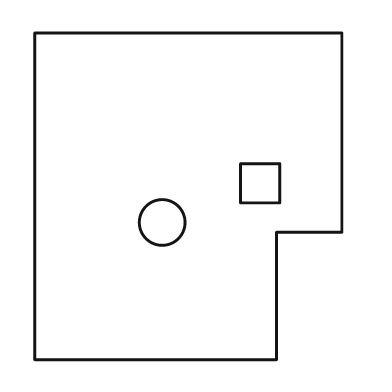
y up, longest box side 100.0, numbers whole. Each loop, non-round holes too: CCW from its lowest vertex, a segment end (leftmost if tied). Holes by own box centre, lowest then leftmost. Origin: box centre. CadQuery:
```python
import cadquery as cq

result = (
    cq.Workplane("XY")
    .moveTo(-47.0, -50.0)
    .lineTo(27.0, -50.0)
    .lineTo(27.0, -11.0)
    .lineTo(47.0, -11.0)
    .lineTo(47.0, 50.0)
    .lineTo(-47.0, 50.0)
    .close()
    .moveTo(-8.0, -8.0)
    .circle(7.0)
    .moveTo(16.0, -2.0)
    .lineTo(28.0, -2.0)
    .lineTo(28.0, 10.0)
    .lineTo(16.0, 10.0)
    .close()
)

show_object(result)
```